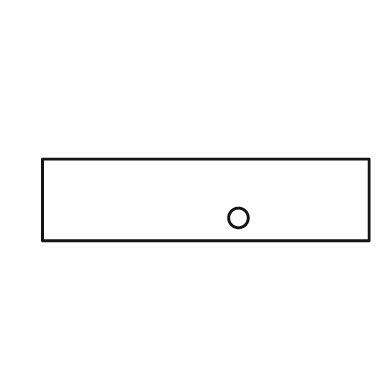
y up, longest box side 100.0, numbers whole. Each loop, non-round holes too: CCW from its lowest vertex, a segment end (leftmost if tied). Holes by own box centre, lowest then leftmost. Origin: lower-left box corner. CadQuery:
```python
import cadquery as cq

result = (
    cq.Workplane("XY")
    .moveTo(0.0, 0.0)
    .lineTo(100.0, 0.0)
    .lineTo(100.0, 25.0)
    .lineTo(0.0, 25.0)
    .close()
    .moveTo(60.0, 7.0)
    .circle(3.0)
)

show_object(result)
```